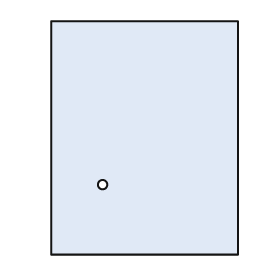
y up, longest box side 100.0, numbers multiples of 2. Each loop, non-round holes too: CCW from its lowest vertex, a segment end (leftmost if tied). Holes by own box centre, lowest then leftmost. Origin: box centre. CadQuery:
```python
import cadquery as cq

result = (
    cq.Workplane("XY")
    .moveTo(-40.0, -50.0)
    .lineTo(40.0, -50.0)
    .lineTo(40.0, 50.0)
    .lineTo(-40.0, 50.0)
    .close()
    .moveTo(-18.0, -20.0)
    .circle(2.0)
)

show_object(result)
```